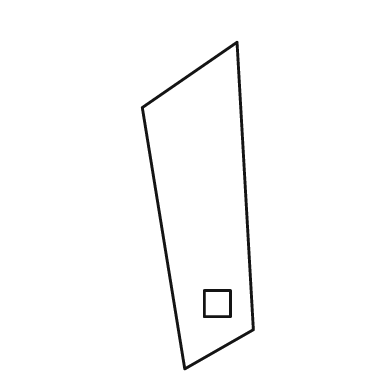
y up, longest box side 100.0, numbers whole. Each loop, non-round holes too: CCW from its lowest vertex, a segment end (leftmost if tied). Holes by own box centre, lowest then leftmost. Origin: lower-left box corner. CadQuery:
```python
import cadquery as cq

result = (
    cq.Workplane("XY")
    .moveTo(13.0, 0.0)
    .lineTo(34.0, 12.0)
    .lineTo(29.0, 100.0)
    .lineTo(0.0, 80.0)
    .close()
    .moveTo(19.0, 16.0)
    .lineTo(27.0, 16.0)
    .lineTo(27.0, 24.0)
    .lineTo(19.0, 24.0)
    .close()
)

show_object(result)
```